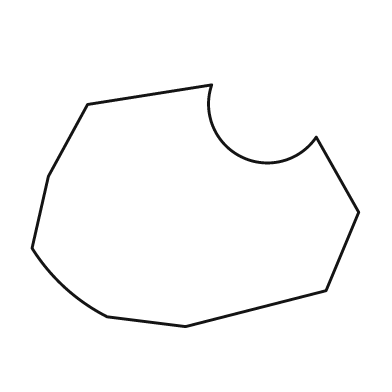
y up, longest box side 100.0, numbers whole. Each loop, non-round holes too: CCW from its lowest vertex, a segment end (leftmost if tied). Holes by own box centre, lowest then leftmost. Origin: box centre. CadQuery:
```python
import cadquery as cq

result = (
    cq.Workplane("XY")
    .moveTo(-3.0, -37.0)
    .lineTo(40.0, -26.0)
    .lineTo(50.0, -2.0)
    .lineTo(37.0, 21.0)
    .threePointArc((14.0, 15.0), (5.0, 37.0))
    .lineTo(-33.0, 31.0)
    .lineTo(-45.0, 9.0)
    .lineTo(-50.0, -13.0)
    .threePointArc((-40.0, -25.0), (-27.0, -34.0))
    .close()
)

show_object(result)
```